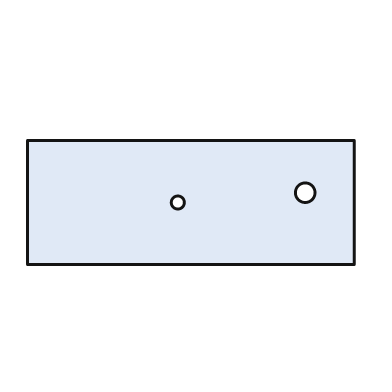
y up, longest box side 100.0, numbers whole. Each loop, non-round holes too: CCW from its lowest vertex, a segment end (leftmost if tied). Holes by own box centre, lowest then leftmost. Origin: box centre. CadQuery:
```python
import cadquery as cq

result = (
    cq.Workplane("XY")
    .moveTo(-50.0, -19.0)
    .lineTo(50.0, -19.0)
    .lineTo(50.0, 19.0)
    .lineTo(-50.0, 19.0)
    .close()
    .moveTo(-4.0, 0.0)
    .circle(2.0)
    .moveTo(35.0, 3.0)
    .circle(3.0)
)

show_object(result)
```